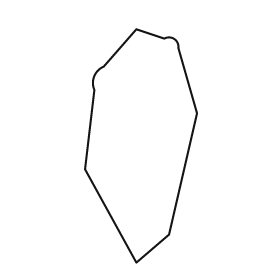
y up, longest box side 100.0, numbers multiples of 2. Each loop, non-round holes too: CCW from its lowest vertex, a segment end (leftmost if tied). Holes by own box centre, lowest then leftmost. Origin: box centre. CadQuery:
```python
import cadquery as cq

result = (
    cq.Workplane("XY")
    .moveTo(-2.0, -50.0)
    .lineTo(12.0, -38.0)
    .lineTo(24.0, 14.0)
    .lineTo(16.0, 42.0)
    .threePointArc((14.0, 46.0), (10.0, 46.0))
    .lineTo(-2.0, 50.0)
    .lineTo(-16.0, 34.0)
    .threePointArc((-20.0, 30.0), (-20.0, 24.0))
    .lineTo(-24.0, -10.0)
    .close()
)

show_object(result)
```